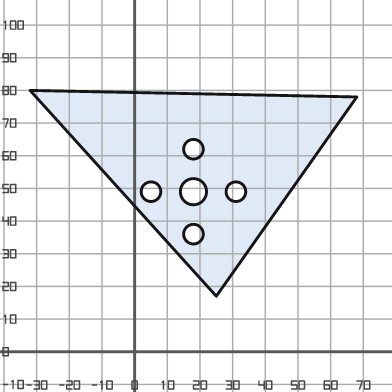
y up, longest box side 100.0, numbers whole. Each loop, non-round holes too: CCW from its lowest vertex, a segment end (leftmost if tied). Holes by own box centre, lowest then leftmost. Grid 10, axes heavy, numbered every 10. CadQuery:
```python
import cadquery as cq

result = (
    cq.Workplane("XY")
    .moveTo(25.0, 17.0)
    .lineTo(68.0, 78.0)
    .lineTo(-32.0, 80.0)
    .close()
    .moveTo(18.0, 36.0)
    .circle(3.0)
    .moveTo(5.0, 49.0)
    .circle(3.0)
    .moveTo(18.0, 49.0)
    .circle(4.0)
    .moveTo(31.0, 49.0)
    .circle(3.0)
    .moveTo(18.0, 62.0)
    .circle(3.0)
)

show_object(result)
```